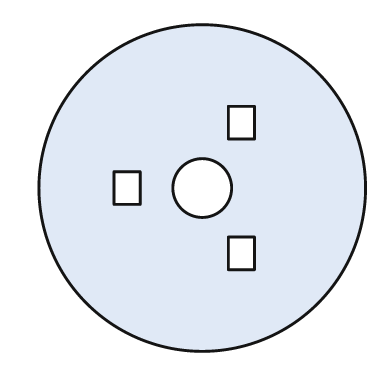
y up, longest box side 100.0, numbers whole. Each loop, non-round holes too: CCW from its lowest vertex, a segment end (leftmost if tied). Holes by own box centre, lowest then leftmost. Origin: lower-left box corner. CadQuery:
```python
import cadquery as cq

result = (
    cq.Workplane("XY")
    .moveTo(50.0, 50.0)
    .circle(50.0)
    .moveTo(58.0, 25.0)
    .lineTo(66.0, 25.0)
    .lineTo(66.0, 35.0)
    .lineTo(58.0, 35.0)
    .close()
    .moveTo(23.0, 45.0)
    .lineTo(31.0, 45.0)
    .lineTo(31.0, 55.0)
    .lineTo(23.0, 55.0)
    .close()
    .moveTo(50.0, 50.0)
    .circle(9.0)
    .moveTo(58.0, 65.0)
    .lineTo(66.0, 65.0)
    .lineTo(66.0, 75.0)
    .lineTo(58.0, 75.0)
    .close()
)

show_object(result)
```